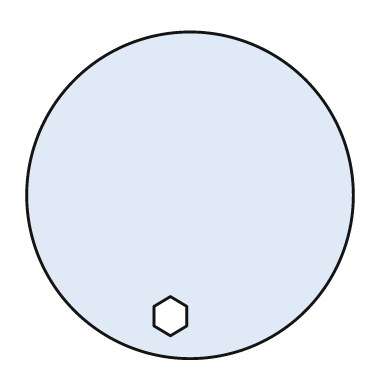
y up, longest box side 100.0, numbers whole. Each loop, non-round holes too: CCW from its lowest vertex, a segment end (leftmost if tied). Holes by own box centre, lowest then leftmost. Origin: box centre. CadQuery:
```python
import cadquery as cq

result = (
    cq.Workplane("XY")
    .moveTo(0.0, 0.0)
    .circle(50.0)
    .moveTo(-6.0, -43.0)
    .lineTo(-1.0, -40.0)
    .lineTo(-1.0, -34.0)
    .lineTo(-6.0, -31.0)
    .lineTo(-11.0, -34.0)
    .lineTo(-11.0, -40.0)
    .close()
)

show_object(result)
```